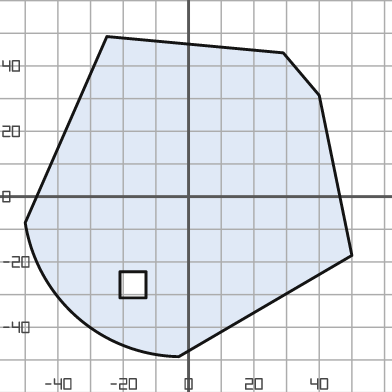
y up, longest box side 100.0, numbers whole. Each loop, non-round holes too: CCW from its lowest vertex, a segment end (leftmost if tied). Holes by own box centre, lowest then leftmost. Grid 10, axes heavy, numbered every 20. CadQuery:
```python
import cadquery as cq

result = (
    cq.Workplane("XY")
    .moveTo(-3.0, -49.0)
    .lineTo(50.0, -18.0)
    .lineTo(40.0, 31.0)
    .lineTo(29.0, 44.0)
    .lineTo(-25.0, 49.0)
    .lineTo(-50.0, -8.0)
    .threePointArc((-34.0, -37.0), (-3.0, -49.0))
    .close()
    .moveTo(-21.0, -31.0)
    .lineTo(-13.0, -31.0)
    .lineTo(-13.0, -23.0)
    .lineTo(-21.0, -23.0)
    .close()
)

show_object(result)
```